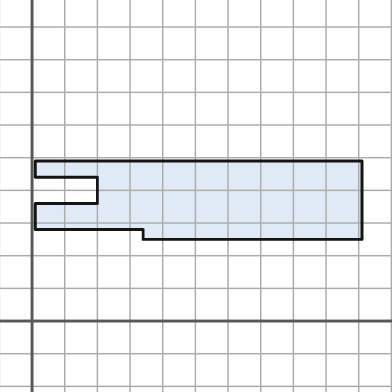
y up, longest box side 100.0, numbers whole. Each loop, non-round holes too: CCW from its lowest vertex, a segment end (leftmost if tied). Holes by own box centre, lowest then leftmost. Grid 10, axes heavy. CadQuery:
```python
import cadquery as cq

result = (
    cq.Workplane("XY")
    .moveTo(34.0, 25.0)
    .lineTo(101.0, 25.0)
    .lineTo(101.0, 49.0)
    .lineTo(1.0, 49.0)
    .lineTo(1.0, 44.0)
    .lineTo(20.0, 44.0)
    .lineTo(20.0, 36.0)
    .lineTo(1.0, 36.0)
    .lineTo(1.0, 28.0)
    .lineTo(34.0, 28.0)
    .close()
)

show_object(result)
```